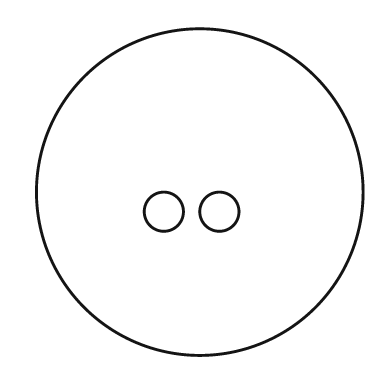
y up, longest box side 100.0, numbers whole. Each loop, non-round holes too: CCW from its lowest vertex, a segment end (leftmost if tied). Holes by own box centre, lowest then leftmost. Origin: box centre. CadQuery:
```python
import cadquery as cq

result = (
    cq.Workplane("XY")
    .moveTo(0.0, 0.0)
    .circle(50.0)
    .moveTo(-11.0, -6.0)
    .circle(6.0)
    .moveTo(6.0, -6.0)
    .circle(6.0)
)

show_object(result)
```